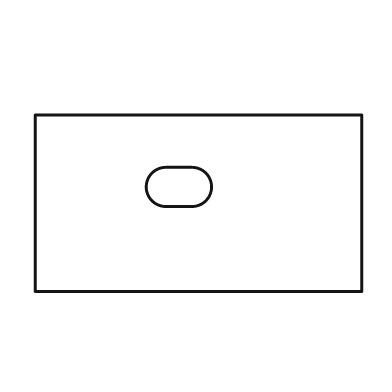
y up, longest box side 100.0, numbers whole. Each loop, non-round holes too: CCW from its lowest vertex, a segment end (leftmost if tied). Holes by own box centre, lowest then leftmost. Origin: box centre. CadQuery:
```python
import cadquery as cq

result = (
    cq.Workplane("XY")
    .moveTo(-50.0, -27.0)
    .lineTo(50.0, -27.0)
    .lineTo(50.0, 27.0)
    .lineTo(-50.0, 27.0)
    .close()
    .moveTo(-10.0, -1.0)
    .lineTo(-2.0, -1.0)
    .threePointArc((4.0, 5.0), (-2.0, 11.0))
    .lineTo(-10.0, 11.0)
    .threePointArc((-16.0, 5.0), (-10.0, -1.0))
    .close()
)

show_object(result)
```